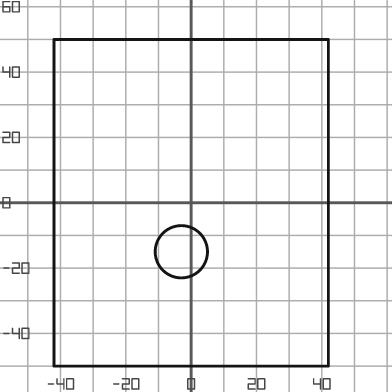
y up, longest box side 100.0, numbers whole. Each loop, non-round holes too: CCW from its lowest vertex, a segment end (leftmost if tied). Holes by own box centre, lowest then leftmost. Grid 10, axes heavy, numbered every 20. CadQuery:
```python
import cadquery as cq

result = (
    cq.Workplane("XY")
    .moveTo(-42.0, -50.0)
    .lineTo(42.0, -50.0)
    .lineTo(42.0, 50.0)
    .lineTo(-42.0, 50.0)
    .close()
    .moveTo(-3.0, -15.0)
    .circle(8.0)
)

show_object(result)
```